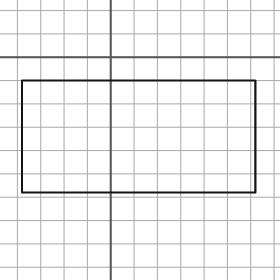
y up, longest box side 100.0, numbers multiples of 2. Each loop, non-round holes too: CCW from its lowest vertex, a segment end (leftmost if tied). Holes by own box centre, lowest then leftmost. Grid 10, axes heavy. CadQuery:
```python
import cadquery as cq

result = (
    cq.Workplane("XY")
    .moveTo(-38.0, -58.0)
    .lineTo(62.0, -58.0)
    .lineTo(62.0, -10.0)
    .lineTo(-38.0, -10.0)
    .close()
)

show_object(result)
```